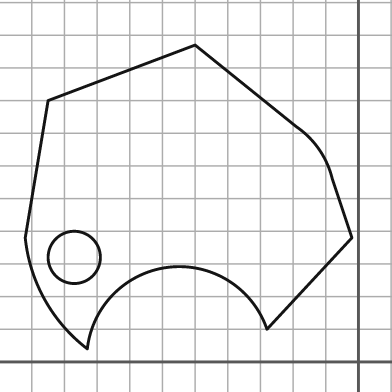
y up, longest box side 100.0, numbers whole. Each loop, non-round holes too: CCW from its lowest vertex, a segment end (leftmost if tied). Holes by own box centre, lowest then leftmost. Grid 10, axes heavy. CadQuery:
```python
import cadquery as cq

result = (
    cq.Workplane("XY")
    .moveTo(-83.0, 4.0)
    .threePointArc((-58.0, 29.0), (-28.0, 10.0))
    .lineTo(-2.0, 38.0)
    .lineTo(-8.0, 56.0)
    .threePointArc((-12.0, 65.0), (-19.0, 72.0))
    .lineTo(-50.0, 97.0)
    .lineTo(-95.0, 80.0)
    .lineTo(-102.0, 38.0)
    .threePointArc((-96.0, 19.0), (-83.0, 4.0))
    .close()
    .moveTo(-87.0, 32.0)
    .circle(8.0)
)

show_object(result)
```